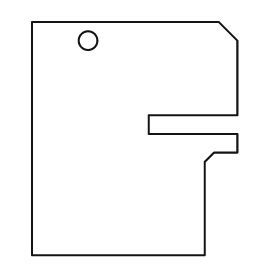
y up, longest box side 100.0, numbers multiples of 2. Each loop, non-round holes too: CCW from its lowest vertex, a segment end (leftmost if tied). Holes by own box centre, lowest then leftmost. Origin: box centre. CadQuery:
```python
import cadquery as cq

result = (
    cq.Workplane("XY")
    .moveTo(-44.0, -50.0)
    .lineTo(30.0, -50.0)
    .lineTo(30.0, -10.0)
    .lineTo(34.0, -6.0)
    .lineTo(44.0, -6.0)
    .lineTo(44.0, 2.0)
    .lineTo(6.0, 2.0)
    .lineTo(6.0, 10.0)
    .lineTo(44.0, 10.0)
    .lineTo(44.0, 42.0)
    .lineTo(36.0, 50.0)
    .lineTo(-44.0, 50.0)
    .close()
    .moveTo(-20.0, 42.0)
    .circle(4.0)
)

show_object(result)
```